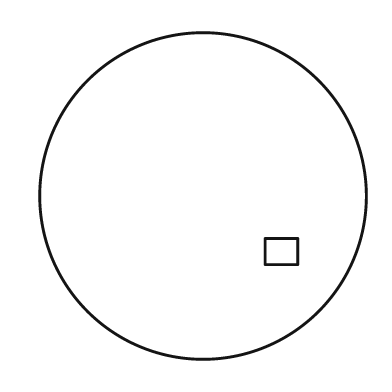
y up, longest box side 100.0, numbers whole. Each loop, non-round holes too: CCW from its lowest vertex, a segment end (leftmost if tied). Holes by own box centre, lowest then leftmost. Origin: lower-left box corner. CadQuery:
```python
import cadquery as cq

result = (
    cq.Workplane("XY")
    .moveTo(50.0, 50.0)
    .circle(50.0)
    .moveTo(69.0, 29.0)
    .lineTo(79.0, 29.0)
    .lineTo(79.0, 37.0)
    .lineTo(69.0, 37.0)
    .close()
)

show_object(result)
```